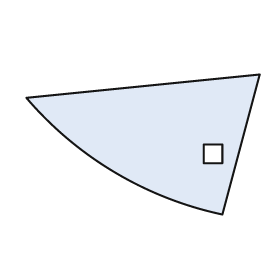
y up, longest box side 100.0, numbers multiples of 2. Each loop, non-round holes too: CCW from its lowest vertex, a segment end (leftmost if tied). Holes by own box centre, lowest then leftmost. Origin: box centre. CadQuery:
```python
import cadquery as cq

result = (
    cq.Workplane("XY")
    .moveTo(34.0, -30.0)
    .lineTo(50.0, 30.0)
    .lineTo(-50.0, 20.0)
    .threePointArc((-12.0, -12.0), (34.0, -30.0))
    .close()
    .moveTo(26.0, -8.0)
    .lineTo(34.0, -8.0)
    .lineTo(34.0, 0.0)
    .lineTo(26.0, 0.0)
    .close()
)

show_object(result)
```